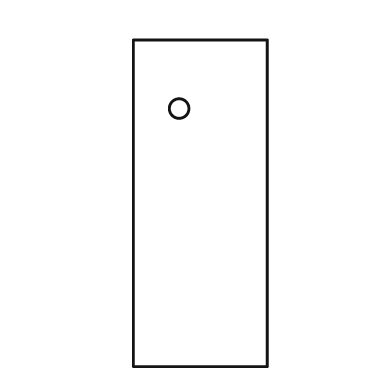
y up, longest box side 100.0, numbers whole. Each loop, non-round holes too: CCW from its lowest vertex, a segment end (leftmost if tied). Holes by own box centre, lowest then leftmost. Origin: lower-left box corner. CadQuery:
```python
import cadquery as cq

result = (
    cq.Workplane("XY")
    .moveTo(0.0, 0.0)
    .lineTo(41.0, 0.0)
    .lineTo(41.0, 100.0)
    .lineTo(0.0, 100.0)
    .close()
    .moveTo(14.0, 79.0)
    .circle(3.0)
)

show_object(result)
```